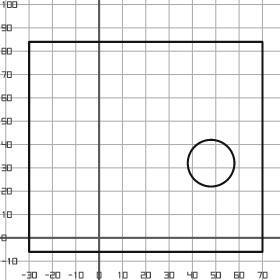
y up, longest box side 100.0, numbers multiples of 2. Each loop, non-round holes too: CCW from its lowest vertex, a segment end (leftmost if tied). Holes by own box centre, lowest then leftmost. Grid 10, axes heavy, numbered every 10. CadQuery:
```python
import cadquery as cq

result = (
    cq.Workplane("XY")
    .moveTo(-30.0, -6.0)
    .lineTo(70.0, -6.0)
    .lineTo(70.0, 84.0)
    .lineTo(-30.0, 84.0)
    .close()
    .moveTo(48.0, 32.0)
    .circle(10.0)
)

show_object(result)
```